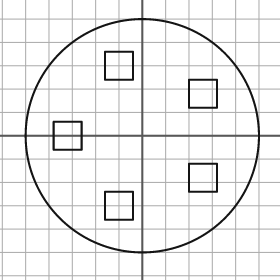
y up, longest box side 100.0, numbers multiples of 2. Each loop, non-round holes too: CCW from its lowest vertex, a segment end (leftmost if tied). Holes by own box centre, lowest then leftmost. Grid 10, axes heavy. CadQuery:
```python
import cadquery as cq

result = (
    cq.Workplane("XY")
    .moveTo(0.0, 0.0)
    .circle(50.0)
    .moveTo(-16.0, -36.0)
    .lineTo(-4.0, -36.0)
    .lineTo(-4.0, -24.0)
    .lineTo(-16.0, -24.0)
    .close()
    .moveTo(20.0, -24.0)
    .lineTo(32.0, -24.0)
    .lineTo(32.0, -12.0)
    .lineTo(20.0, -12.0)
    .close()
    .moveTo(-38.0, -6.0)
    .lineTo(-26.0, -6.0)
    .lineTo(-26.0, 6.0)
    .lineTo(-38.0, 6.0)
    .close()
    .moveTo(20.0, 12.0)
    .lineTo(32.0, 12.0)
    .lineTo(32.0, 24.0)
    .lineTo(20.0, 24.0)
    .close()
    .moveTo(-16.0, 24.0)
    .lineTo(-4.0, 24.0)
    .lineTo(-4.0, 36.0)
    .lineTo(-16.0, 36.0)
    .close()
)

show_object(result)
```